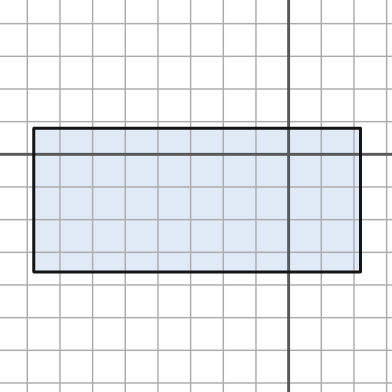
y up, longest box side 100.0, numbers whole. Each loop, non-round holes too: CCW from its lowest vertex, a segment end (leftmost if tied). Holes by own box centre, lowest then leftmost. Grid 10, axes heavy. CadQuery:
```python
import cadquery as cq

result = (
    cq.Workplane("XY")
    .moveTo(-78.0, -36.0)
    .lineTo(22.0, -36.0)
    .lineTo(22.0, 8.0)
    .lineTo(-78.0, 8.0)
    .close()
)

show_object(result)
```